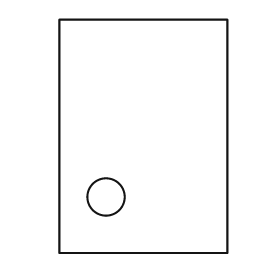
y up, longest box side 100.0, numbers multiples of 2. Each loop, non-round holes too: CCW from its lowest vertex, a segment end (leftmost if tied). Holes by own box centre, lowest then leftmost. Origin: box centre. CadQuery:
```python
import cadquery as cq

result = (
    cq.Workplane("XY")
    .moveTo(-36.0, -50.0)
    .lineTo(36.0, -50.0)
    .lineTo(36.0, 50.0)
    .lineTo(-36.0, 50.0)
    .close()
    .moveTo(-16.0, -26.0)
    .circle(8.0)
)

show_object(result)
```